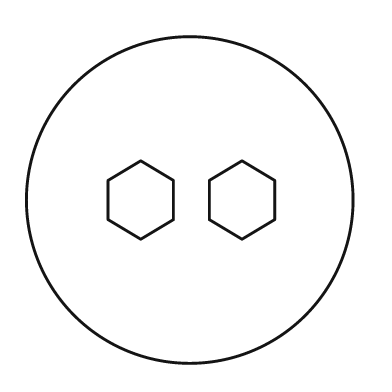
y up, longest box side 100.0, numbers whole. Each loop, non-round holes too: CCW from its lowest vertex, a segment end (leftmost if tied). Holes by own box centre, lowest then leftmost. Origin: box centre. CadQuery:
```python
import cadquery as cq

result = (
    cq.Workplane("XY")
    .moveTo(0.0, 0.0)
    .circle(50.0)
    .moveTo(-15.0, -12.0)
    .lineTo(-5.0, -6.0)
    .lineTo(-5.0, 6.0)
    .lineTo(-15.0, 12.0)
    .lineTo(-25.0, 6.0)
    .lineTo(-25.0, -6.0)
    .close()
    .moveTo(16.0, -12.0)
    .lineTo(26.0, -6.0)
    .lineTo(26.0, 6.0)
    .lineTo(16.0, 12.0)
    .lineTo(6.0, 6.0)
    .lineTo(6.0, -6.0)
    .close()
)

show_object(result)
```